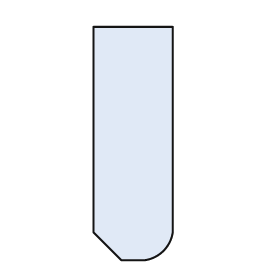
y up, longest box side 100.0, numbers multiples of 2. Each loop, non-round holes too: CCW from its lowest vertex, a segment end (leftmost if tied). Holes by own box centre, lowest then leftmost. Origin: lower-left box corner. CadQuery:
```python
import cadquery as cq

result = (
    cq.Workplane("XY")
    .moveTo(12.0, 0.0)
    .lineTo(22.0, 0.0)
    .threePointArc((30.0, 4.0), (34.0, 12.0))
    .lineTo(34.0, 100.0)
    .lineTo(0.0, 100.0)
    .lineTo(0.0, 12.0)
    .close()
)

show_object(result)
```